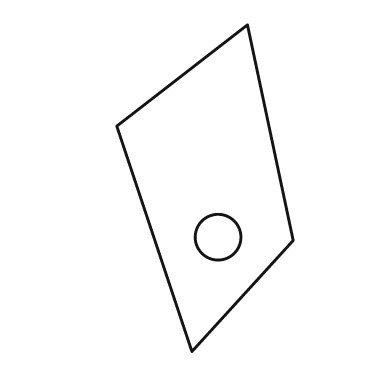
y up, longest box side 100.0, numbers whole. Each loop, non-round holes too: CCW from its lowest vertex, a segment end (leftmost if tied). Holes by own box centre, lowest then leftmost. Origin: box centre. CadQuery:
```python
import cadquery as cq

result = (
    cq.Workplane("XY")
    .moveTo(-4.0, -50.0)
    .lineTo(27.0, -16.0)
    .lineTo(13.0, 50.0)
    .lineTo(-27.0, 19.0)
    .close()
    .moveTo(4.0, -15.0)
    .circle(7.0)
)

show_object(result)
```